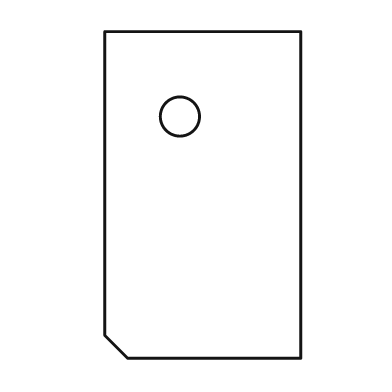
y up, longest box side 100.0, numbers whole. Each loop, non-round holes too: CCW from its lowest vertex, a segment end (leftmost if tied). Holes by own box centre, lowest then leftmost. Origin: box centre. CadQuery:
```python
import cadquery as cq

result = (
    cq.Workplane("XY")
    .moveTo(-23.0, -50.0)
    .lineTo(30.0, -50.0)
    .lineTo(30.0, 50.0)
    .lineTo(-30.0, 50.0)
    .lineTo(-30.0, -43.0)
    .close()
    .moveTo(-7.0, 24.0)
    .circle(6.0)
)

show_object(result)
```